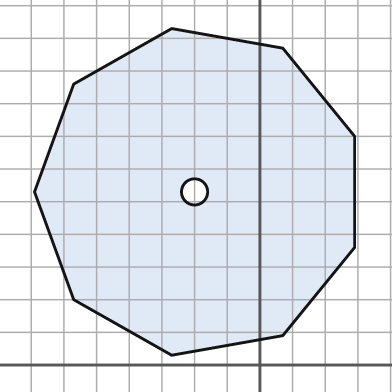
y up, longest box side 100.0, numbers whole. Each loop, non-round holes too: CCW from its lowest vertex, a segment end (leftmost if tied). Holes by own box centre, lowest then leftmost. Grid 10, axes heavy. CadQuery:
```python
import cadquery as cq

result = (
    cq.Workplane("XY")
    .moveTo(-27.0, 3.0)
    .lineTo(7.0, 9.0)
    .lineTo(29.0, 36.0)
    .lineTo(29.0, 70.0)
    .lineTo(7.0, 97.0)
    .lineTo(-27.0, 103.0)
    .lineTo(-57.0, 86.0)
    .lineTo(-69.0, 53.0)
    .lineTo(-57.0, 20.0)
    .close()
    .moveTo(-20.0, 53.0)
    .circle(4.0)
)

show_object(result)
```